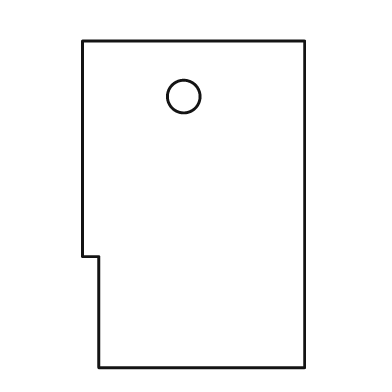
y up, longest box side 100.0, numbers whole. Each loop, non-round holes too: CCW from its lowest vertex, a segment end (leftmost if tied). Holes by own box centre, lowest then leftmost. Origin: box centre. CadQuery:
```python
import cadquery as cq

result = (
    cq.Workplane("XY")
    .moveTo(-29.0, -50.0)
    .lineTo(34.0, -50.0)
    .lineTo(34.0, 50.0)
    .lineTo(-34.0, 50.0)
    .lineTo(-34.0, -16.0)
    .lineTo(-29.0, -16.0)
    .close()
    .moveTo(-3.0, 33.0)
    .circle(5.0)
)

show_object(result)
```